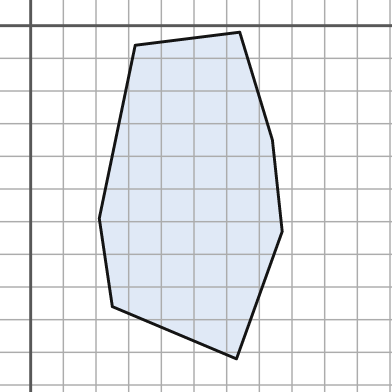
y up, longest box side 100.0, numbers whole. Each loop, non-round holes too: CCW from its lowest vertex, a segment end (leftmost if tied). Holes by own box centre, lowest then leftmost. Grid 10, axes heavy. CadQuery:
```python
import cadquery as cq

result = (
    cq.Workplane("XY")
    .moveTo(63.0, -102.0)
    .lineTo(77.0, -63.0)
    .lineTo(74.0, -35.0)
    .lineTo(64.0, -2.0)
    .lineTo(32.0, -6.0)
    .lineTo(21.0, -59.0)
    .lineTo(25.0, -86.0)
    .close()
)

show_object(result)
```